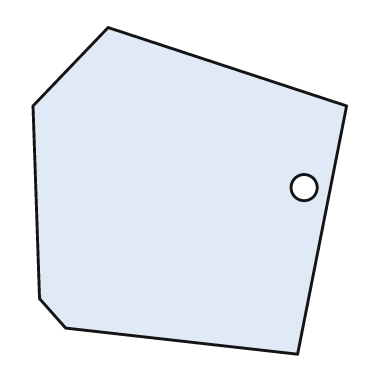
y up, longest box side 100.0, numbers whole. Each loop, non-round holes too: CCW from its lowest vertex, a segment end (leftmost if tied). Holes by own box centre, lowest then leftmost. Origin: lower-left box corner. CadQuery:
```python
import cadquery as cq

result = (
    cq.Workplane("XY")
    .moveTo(81.0, 0.0)
    .lineTo(96.0, 76.0)
    .lineTo(23.0, 100.0)
    .lineTo(0.0, 76.0)
    .lineTo(2.0, 17.0)
    .lineTo(10.0, 8.0)
    .close()
    .moveTo(83.0, 51.0)
    .circle(4.0)
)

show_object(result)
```